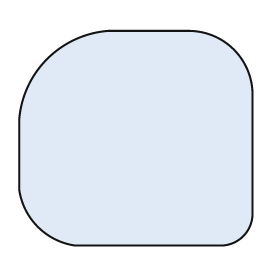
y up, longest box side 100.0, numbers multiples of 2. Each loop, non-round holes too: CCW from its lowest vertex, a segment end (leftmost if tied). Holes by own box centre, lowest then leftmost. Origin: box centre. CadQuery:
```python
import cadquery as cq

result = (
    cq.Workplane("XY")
    .moveTo(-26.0, -46.0)
    .lineTo(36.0, -46.0)
    .threePointArc((46.0, -42.0), (50.0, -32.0))
    .lineTo(50.0, 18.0)
    .threePointArc((42.0, 38.0), (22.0, 46.0))
    .lineTo(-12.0, 46.0)
    .threePointArc((-38.0, 34.0), (-50.0, 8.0))
    .lineTo(-50.0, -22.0)
    .threePointArc((-42.0, -38.0), (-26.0, -46.0))
    .close()
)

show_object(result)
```